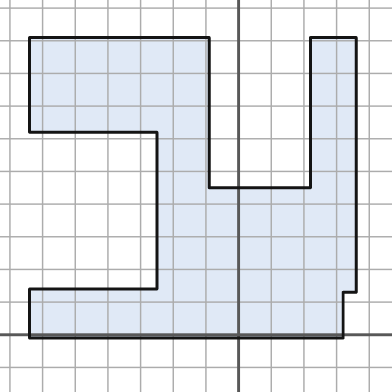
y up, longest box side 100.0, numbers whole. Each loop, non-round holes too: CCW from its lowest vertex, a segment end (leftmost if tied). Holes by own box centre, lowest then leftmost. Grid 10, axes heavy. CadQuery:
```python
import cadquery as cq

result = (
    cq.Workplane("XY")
    .moveTo(-64.0, -1.0)
    .lineTo(32.0, -1.0)
    .lineTo(32.0, 13.0)
    .lineTo(36.0, 13.0)
    .lineTo(36.0, 91.0)
    .lineTo(22.0, 91.0)
    .lineTo(22.0, 45.0)
    .lineTo(-9.0, 45.0)
    .lineTo(-9.0, 91.0)
    .lineTo(-64.0, 91.0)
    .lineTo(-64.0, 62.0)
    .lineTo(-25.0, 62.0)
    .lineTo(-25.0, 14.0)
    .lineTo(-64.0, 14.0)
    .close()
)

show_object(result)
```